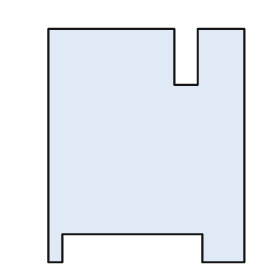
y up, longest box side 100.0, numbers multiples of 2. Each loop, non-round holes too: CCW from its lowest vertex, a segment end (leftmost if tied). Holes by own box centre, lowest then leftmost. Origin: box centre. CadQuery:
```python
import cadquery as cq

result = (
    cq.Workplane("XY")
    .moveTo(-42.0, -50.0)
    .lineTo(-36.0, -50.0)
    .lineTo(-36.0, -38.0)
    .lineTo(24.0, -38.0)
    .lineTo(24.0, -50.0)
    .lineTo(42.0, -50.0)
    .lineTo(42.0, 50.0)
    .lineTo(22.0, 50.0)
    .lineTo(22.0, 26.0)
    .lineTo(12.0, 26.0)
    .lineTo(12.0, 50.0)
    .lineTo(-42.0, 50.0)
    .close()
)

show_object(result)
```